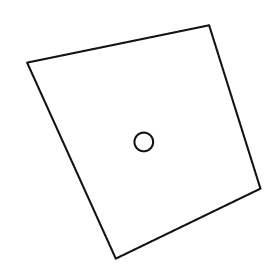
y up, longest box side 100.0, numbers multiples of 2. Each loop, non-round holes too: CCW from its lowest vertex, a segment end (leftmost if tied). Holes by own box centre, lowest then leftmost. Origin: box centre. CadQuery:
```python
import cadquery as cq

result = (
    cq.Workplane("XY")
    .moveTo(-12.0, -50.0)
    .lineTo(50.0, -20.0)
    .lineTo(28.0, 50.0)
    .lineTo(-50.0, 34.0)
    .close()
    .moveTo(0.0, 0.0)
    .circle(4.0)
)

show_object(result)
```